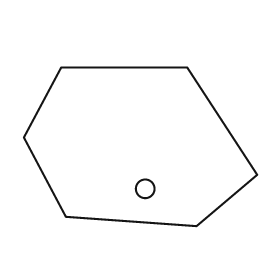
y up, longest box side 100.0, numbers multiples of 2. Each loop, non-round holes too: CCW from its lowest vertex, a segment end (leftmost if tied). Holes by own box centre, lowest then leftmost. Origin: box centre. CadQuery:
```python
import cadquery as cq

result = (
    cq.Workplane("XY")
    .moveTo(24.0, -34.0)
    .lineTo(50.0, -12.0)
    .lineTo(20.0, 34.0)
    .lineTo(-34.0, 34.0)
    .lineTo(-50.0, 4.0)
    .lineTo(-32.0, -30.0)
    .close()
    .moveTo(2.0, -18.0)
    .circle(4.0)
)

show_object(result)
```